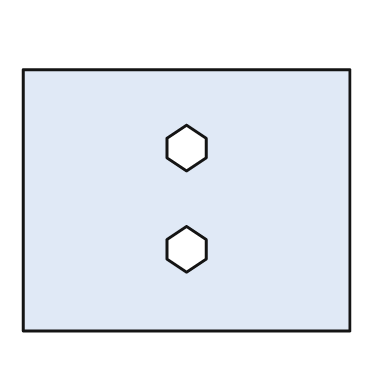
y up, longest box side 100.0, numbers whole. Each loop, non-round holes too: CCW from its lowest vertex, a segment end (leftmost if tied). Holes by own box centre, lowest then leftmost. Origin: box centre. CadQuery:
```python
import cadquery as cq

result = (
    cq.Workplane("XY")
    .moveTo(-50.0, -40.0)
    .lineTo(50.0, -40.0)
    .lineTo(50.0, 40.0)
    .lineTo(-50.0, 40.0)
    .close()
    .moveTo(0.0, -22.0)
    .lineTo(6.0, -18.0)
    .lineTo(6.0, -12.0)
    .lineTo(0.0, -8.0)
    .lineTo(-6.0, -12.0)
    .lineTo(-6.0, -18.0)
    .close()
    .moveTo(0.0, 9.0)
    .lineTo(6.0, 13.0)
    .lineTo(6.0, 19.0)
    .lineTo(0.0, 23.0)
    .lineTo(-6.0, 19.0)
    .lineTo(-6.0, 13.0)
    .close()
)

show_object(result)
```